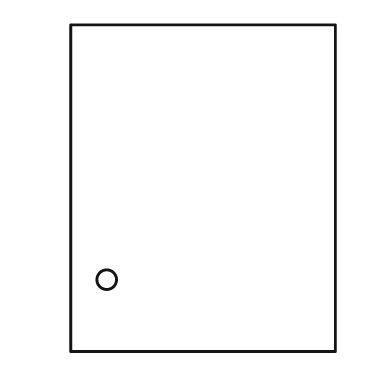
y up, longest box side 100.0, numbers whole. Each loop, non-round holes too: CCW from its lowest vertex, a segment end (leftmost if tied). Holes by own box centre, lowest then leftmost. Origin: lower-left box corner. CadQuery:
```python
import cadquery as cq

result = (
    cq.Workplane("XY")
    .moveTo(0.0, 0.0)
    .lineTo(81.0, 0.0)
    .lineTo(81.0, 100.0)
    .lineTo(0.0, 100.0)
    .close()
    .moveTo(11.0, 22.0)
    .circle(3.0)
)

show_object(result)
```